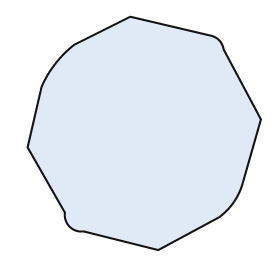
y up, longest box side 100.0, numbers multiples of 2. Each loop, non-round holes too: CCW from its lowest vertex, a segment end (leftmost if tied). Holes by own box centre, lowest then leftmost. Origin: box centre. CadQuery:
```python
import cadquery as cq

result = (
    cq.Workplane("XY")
    .moveTo(6.0, -50.0)
    .lineTo(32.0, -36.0)
    .threePointArc((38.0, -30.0), (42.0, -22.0))
    .lineTo(50.0, 6.0)
    .lineTo(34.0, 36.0)
    .threePointArc((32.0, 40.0), (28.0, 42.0))
    .lineTo(-6.0, 50.0)
    .lineTo(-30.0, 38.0)
    .threePointArc((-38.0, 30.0), (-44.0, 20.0))
    .lineTo(-50.0, -6.0)
    .lineTo(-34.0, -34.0)
    .threePointArc((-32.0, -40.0), (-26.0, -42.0))
    .close()
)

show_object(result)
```